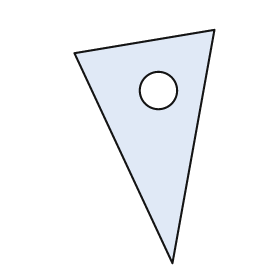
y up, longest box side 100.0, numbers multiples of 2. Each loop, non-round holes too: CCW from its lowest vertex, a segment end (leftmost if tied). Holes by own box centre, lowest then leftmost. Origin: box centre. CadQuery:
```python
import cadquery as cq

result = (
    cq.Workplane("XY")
    .moveTo(12.0, -50.0)
    .lineTo(30.0, 50.0)
    .lineTo(-30.0, 40.0)
    .close()
    .moveTo(6.0, 24.0)
    .circle(8.0)
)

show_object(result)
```